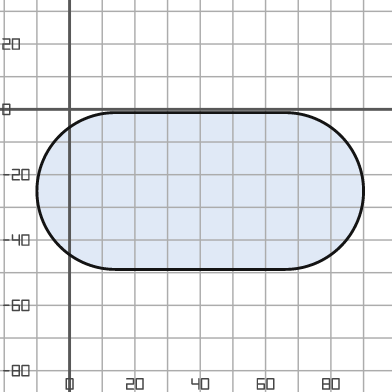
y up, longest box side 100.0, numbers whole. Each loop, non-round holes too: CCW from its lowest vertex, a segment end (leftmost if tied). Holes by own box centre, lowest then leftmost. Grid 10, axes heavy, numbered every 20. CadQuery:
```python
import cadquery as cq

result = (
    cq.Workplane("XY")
    .moveTo(14.0, -49.0)
    .lineTo(66.0, -49.0)
    .threePointArc((90.0, -25.0), (66.0, -1.0))
    .lineTo(14.0, -1.0)
    .threePointArc((-10.0, -25.0), (14.0, -49.0))
    .close()
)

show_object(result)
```